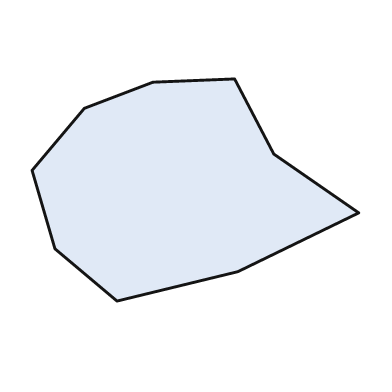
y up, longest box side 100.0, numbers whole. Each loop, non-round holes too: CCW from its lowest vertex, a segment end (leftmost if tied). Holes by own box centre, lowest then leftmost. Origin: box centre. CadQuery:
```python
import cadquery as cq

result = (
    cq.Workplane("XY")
    .moveTo(-24.0, -34.0)
    .lineTo(13.0, -25.0)
    .lineTo(50.0, -7.0)
    .lineTo(24.0, 11.0)
    .lineTo(12.0, 34.0)
    .lineTo(-13.0, 33.0)
    .lineTo(-34.0, 25.0)
    .lineTo(-50.0, 6.0)
    .lineTo(-43.0, -18.0)
    .close()
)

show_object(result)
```